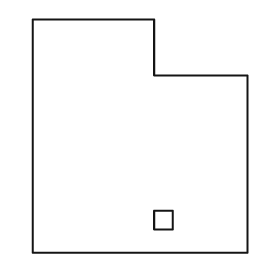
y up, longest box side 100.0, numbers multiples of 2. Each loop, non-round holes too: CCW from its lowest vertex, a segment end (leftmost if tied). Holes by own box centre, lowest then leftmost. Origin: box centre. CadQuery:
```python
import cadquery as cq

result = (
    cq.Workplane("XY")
    .moveTo(-46.0, -50.0)
    .lineTo(46.0, -50.0)
    .lineTo(46.0, 26.0)
    .lineTo(6.0, 26.0)
    .lineTo(6.0, 50.0)
    .lineTo(-46.0, 50.0)
    .close()
    .moveTo(6.0, -40.0)
    .lineTo(14.0, -40.0)
    .lineTo(14.0, -32.0)
    .lineTo(6.0, -32.0)
    .close()
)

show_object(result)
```